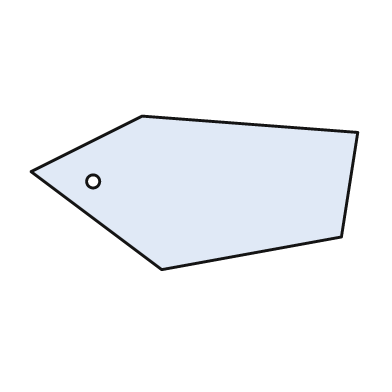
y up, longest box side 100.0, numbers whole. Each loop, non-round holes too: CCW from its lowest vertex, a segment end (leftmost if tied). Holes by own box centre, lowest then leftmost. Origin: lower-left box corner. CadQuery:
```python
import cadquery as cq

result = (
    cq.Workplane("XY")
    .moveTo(40.0, 0.0)
    .lineTo(95.0, 10.0)
    .lineTo(100.0, 42.0)
    .lineTo(34.0, 47.0)
    .lineTo(0.0, 30.0)
    .close()
    .moveTo(19.0, 27.0)
    .circle(2.0)
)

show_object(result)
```